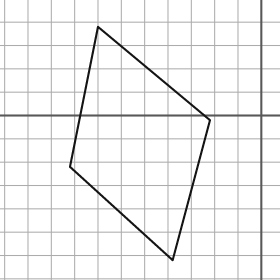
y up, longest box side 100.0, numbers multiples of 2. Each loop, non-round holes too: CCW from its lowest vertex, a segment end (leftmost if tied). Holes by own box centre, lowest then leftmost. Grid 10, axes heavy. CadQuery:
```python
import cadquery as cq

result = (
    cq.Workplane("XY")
    .moveTo(-38.0, -62.0)
    .lineTo(-22.0, -2.0)
    .lineTo(-70.0, 38.0)
    .lineTo(-82.0, -22.0)
    .close()
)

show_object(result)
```